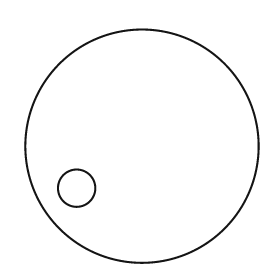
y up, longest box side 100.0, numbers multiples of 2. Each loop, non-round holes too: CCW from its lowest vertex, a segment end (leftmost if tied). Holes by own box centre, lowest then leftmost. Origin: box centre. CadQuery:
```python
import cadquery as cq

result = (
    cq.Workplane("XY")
    .moveTo(0.0, 0.0)
    .circle(50.0)
    .moveTo(-28.0, -18.0)
    .circle(8.0)
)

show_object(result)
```